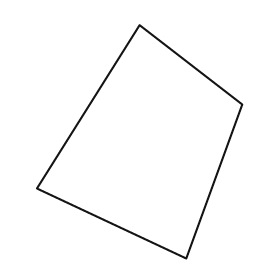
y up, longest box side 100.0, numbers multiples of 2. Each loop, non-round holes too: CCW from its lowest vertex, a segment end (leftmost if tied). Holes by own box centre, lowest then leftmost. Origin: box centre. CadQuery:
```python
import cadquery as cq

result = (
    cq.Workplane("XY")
    .moveTo(20.0, -50.0)
    .lineTo(44.0, 16.0)
    .lineTo(0.0, 50.0)
    .lineTo(-44.0, -20.0)
    .close()
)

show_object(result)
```